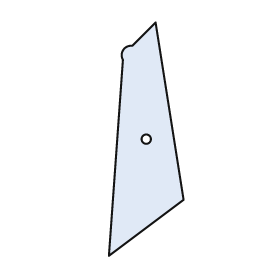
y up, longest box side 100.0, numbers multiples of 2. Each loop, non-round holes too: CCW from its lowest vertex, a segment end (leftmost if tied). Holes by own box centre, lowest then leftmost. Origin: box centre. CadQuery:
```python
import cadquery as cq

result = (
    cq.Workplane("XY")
    .moveTo(-16.0, -50.0)
    .lineTo(16.0, -26.0)
    .lineTo(4.0, 50.0)
    .lineTo(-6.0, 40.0)
    .threePointArc((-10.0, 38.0), (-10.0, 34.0))
    .close()
    .moveTo(0.0, 0.0)
    .circle(2.0)
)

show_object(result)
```